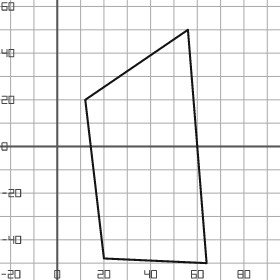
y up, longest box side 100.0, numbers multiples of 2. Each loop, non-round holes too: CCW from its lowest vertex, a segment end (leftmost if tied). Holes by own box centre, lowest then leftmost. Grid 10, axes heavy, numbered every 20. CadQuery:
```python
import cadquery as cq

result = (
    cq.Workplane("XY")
    .moveTo(64.0, -50.0)
    .lineTo(56.0, 50.0)
    .lineTo(12.0, 20.0)
    .lineTo(20.0, -48.0)
    .close()
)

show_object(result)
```